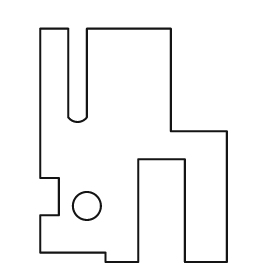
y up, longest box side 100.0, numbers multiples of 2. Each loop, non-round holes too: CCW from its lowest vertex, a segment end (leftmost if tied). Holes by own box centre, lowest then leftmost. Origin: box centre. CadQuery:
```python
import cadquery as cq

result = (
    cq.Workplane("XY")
    .moveTo(-12.0, -50.0)
    .lineTo(2.0, -50.0)
    .lineTo(2.0, -6.0)
    .lineTo(22.0, -6.0)
    .lineTo(22.0, -50.0)
    .lineTo(40.0, -50.0)
    .lineTo(40.0, 6.0)
    .lineTo(16.0, 6.0)
    .lineTo(16.0, 50.0)
    .lineTo(-20.0, 50.0)
    .lineTo(-20.0, 12.0)
    .threePointArc((-24.0, 10.0), (-28.0, 12.0))
    .lineTo(-28.0, 50.0)
    .lineTo(-40.0, 50.0)
    .lineTo(-40.0, -14.0)
    .lineTo(-32.0, -14.0)
    .lineTo(-32.0, -30.0)
    .lineTo(-40.0, -30.0)
    .lineTo(-40.0, -46.0)
    .lineTo(-12.0, -46.0)
    .close()
    .moveTo(-20.0, -26.0)
    .circle(6.0)
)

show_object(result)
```